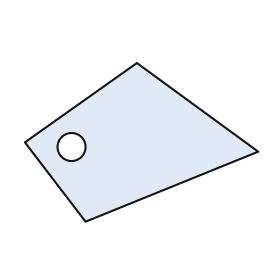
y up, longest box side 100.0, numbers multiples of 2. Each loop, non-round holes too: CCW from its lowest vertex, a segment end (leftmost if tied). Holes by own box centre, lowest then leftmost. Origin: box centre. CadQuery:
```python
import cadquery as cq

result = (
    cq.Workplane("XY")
    .moveTo(-24.0, -34.0)
    .lineTo(50.0, -4.0)
    .lineTo(-2.0, 34.0)
    .lineTo(-50.0, 0.0)
    .close()
    .moveTo(-30.0, -2.0)
    .circle(6.0)
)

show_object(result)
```